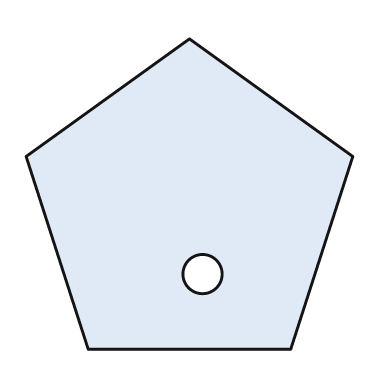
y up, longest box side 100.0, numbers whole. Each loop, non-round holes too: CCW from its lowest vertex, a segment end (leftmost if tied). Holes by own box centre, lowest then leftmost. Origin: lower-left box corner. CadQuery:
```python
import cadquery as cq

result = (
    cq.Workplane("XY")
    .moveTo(19.0, 0.0)
    .lineTo(81.0, 0.0)
    .lineTo(100.0, 59.0)
    .lineTo(50.0, 95.0)
    .lineTo(0.0, 59.0)
    .close()
    .moveTo(54.0, 23.0)
    .circle(6.0)
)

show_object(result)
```